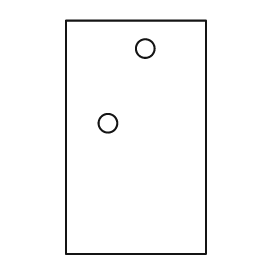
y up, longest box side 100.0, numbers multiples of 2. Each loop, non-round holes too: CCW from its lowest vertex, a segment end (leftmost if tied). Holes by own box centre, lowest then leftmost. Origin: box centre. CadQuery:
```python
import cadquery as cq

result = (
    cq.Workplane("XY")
    .moveTo(-30.0, -50.0)
    .lineTo(30.0, -50.0)
    .lineTo(30.0, 50.0)
    .lineTo(-30.0, 50.0)
    .close()
    .moveTo(-12.0, 6.0)
    .circle(4.0)
    .moveTo(4.0, 38.0)
    .circle(4.0)
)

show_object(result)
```